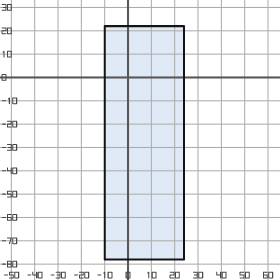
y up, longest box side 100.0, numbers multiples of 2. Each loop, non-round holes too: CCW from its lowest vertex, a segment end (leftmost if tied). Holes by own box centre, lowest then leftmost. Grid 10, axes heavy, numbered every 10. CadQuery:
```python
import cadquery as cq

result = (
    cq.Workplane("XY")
    .moveTo(-10.0, -78.0)
    .lineTo(24.0, -78.0)
    .lineTo(24.0, 22.0)
    .lineTo(-10.0, 22.0)
    .close()
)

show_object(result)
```